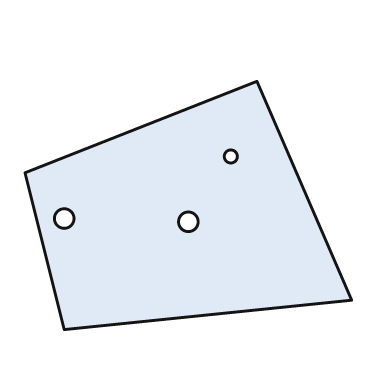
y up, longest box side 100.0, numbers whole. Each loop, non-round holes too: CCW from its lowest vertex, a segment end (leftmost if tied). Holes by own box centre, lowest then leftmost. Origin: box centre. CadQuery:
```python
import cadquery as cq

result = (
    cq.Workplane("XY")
    .moveTo(-38.0, -38.0)
    .lineTo(50.0, -29.0)
    .lineTo(21.0, 38.0)
    .lineTo(-50.0, 10.0)
    .close()
    .moveTo(0.0, -5.0)
    .circle(3.0)
    .moveTo(-38.0, -4.0)
    .circle(3.0)
    .moveTo(13.0, 15.0)
    .circle(2.0)
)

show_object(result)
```